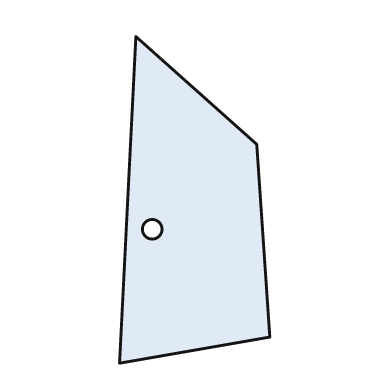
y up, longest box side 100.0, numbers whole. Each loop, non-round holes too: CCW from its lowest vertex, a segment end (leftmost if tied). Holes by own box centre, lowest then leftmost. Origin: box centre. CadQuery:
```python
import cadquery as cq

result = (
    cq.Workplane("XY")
    .moveTo(-23.0, -50.0)
    .lineTo(23.0, -42.0)
    .lineTo(19.0, 17.0)
    .lineTo(-18.0, 50.0)
    .close()
    .moveTo(-13.0, -9.0)
    .circle(3.0)
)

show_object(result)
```